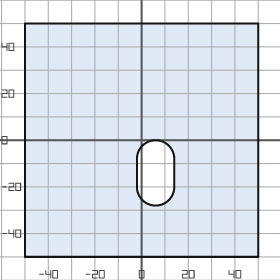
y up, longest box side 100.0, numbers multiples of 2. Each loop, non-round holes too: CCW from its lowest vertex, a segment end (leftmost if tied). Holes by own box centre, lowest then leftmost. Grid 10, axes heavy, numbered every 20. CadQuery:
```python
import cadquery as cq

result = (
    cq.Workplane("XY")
    .moveTo(-50.0, -50.0)
    .lineTo(50.0, -50.0)
    .lineTo(50.0, 50.0)
    .lineTo(-50.0, 50.0)
    .close()
    .moveTo(-2.0, -20.0)
    .threePointArc((6.0, -28.0), (14.0, -20.0))
    .lineTo(14.0, -8.0)
    .threePointArc((6.0, 0.0), (-2.0, -8.0))
    .close()
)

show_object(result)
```